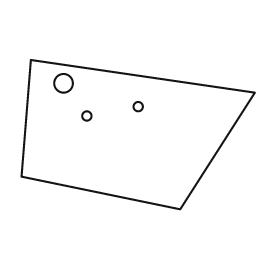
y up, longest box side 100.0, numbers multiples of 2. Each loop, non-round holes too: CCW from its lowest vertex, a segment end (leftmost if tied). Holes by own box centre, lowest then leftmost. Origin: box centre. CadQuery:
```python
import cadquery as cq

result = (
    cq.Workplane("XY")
    .moveTo(18.0, -32.0)
    .lineTo(50.0, 18.0)
    .lineTo(-46.0, 32.0)
    .lineTo(-50.0, -18.0)
    .close()
    .moveTo(-22.0, 8.0)
    .circle(2.0)
    .moveTo(0.0, 12.0)
    .circle(2.0)
    .moveTo(-32.0, 22.0)
    .circle(4.0)
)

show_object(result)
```